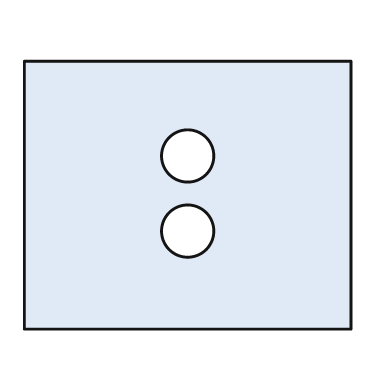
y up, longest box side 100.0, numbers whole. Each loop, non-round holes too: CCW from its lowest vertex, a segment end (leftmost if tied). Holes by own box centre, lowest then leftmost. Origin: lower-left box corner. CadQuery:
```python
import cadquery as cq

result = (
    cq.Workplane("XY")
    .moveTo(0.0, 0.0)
    .lineTo(100.0, 0.0)
    .lineTo(100.0, 82.0)
    .lineTo(0.0, 82.0)
    .close()
    .moveTo(50.0, 30.0)
    .circle(8.0)
    .moveTo(50.0, 53.0)
    .circle(8.0)
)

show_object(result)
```